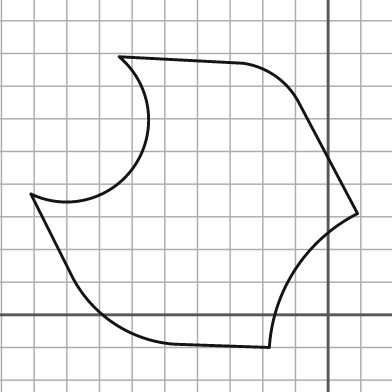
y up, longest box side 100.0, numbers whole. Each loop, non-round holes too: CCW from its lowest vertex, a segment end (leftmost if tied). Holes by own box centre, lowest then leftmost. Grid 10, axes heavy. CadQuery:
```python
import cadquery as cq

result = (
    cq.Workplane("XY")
    .moveTo(-18.0, -10.0)
    .threePointArc((-10.0, 14.0), (9.0, 31.0))
    .lineTo(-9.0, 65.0)
    .threePointArc((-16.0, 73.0), (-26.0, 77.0))
    .lineTo(-64.0, 79.0)
    .threePointArc((-59.0, 46.0), (-91.0, 37.0))
    .lineTo(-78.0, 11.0)
    .threePointArc((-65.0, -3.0), (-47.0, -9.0))
    .close()
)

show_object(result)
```